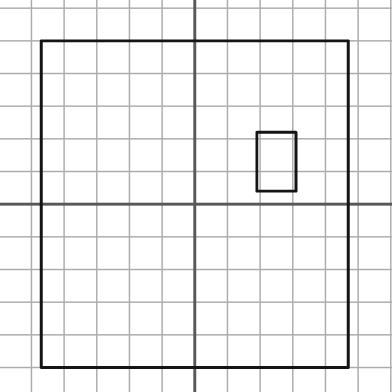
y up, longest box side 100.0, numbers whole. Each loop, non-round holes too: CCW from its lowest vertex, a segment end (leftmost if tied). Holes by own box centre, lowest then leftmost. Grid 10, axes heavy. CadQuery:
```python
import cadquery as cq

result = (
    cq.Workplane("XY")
    .moveTo(-47.0, -50.0)
    .lineTo(47.0, -50.0)
    .lineTo(47.0, 50.0)
    .lineTo(-47.0, 50.0)
    .close()
    .moveTo(19.0, 4.0)
    .lineTo(31.0, 4.0)
    .lineTo(31.0, 22.0)
    .lineTo(19.0, 22.0)
    .close()
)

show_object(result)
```